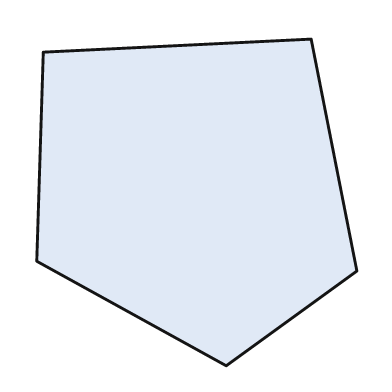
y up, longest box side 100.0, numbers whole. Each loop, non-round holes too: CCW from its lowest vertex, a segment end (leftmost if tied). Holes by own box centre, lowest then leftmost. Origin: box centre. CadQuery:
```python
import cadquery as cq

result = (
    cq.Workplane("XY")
    .moveTo(9.0, -50.0)
    .lineTo(49.0, -21.0)
    .lineTo(35.0, 50.0)
    .lineTo(-47.0, 46.0)
    .lineTo(-49.0, -18.0)
    .close()
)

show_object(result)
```